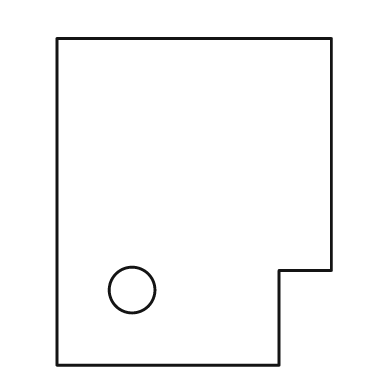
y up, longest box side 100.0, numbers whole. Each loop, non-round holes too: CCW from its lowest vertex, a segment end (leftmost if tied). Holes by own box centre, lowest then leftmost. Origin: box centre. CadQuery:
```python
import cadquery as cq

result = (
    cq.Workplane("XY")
    .moveTo(-42.0, -50.0)
    .lineTo(26.0, -50.0)
    .lineTo(26.0, -21.0)
    .lineTo(42.0, -21.0)
    .lineTo(42.0, 50.0)
    .lineTo(-42.0, 50.0)
    .close()
    .moveTo(-19.0, -27.0)
    .circle(7.0)
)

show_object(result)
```